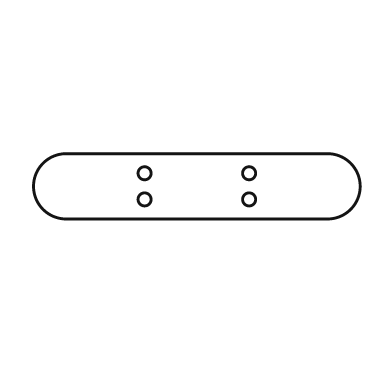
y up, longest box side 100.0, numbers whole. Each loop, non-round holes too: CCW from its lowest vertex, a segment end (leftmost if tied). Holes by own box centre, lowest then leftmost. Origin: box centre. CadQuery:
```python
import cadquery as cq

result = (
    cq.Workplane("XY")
    .moveTo(-40.0, -10.0)
    .lineTo(40.0, -10.0)
    .threePointArc((50.0, 0.0), (40.0, 10.0))
    .lineTo(-40.0, 10.0)
    .threePointArc((-50.0, 0.0), (-40.0, -10.0))
    .close()
    .moveTo(-16.0, -4.0)
    .circle(2.0)
    .moveTo(16.0, -4.0)
    .circle(2.0)
    .moveTo(-16.0, 4.0)
    .circle(2.0)
    .moveTo(16.0, 4.0)
    .circle(2.0)
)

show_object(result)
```